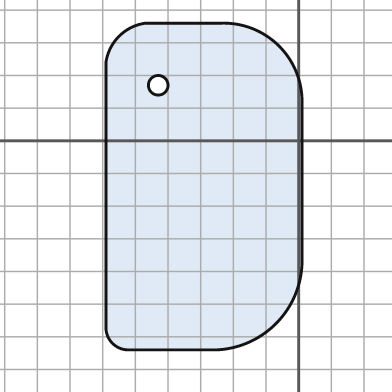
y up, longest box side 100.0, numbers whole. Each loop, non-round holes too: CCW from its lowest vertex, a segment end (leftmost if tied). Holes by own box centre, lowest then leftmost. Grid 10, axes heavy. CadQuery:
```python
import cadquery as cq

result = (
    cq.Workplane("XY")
    .moveTo(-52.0, -64.0)
    .lineTo(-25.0, -64.0)
    .threePointArc((-7.0, -56.0), (1.0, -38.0))
    .lineTo(1.0, 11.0)
    .threePointArc((-6.0, 29.0), (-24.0, 36.0))
    .lineTo(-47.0, 36.0)
    .threePointArc((-55.0, 32.0), (-59.0, 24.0))
    .lineTo(-59.0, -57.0)
    .threePointArc((-57.0, -62.0), (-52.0, -64.0))
    .close()
    .moveTo(-43.0, 17.0)
    .circle(3.0)
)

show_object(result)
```